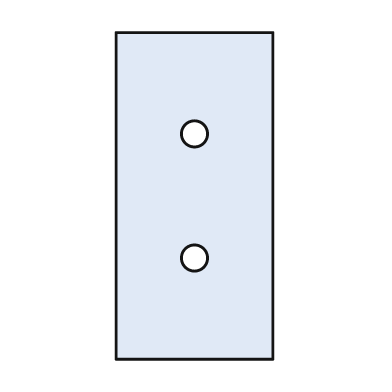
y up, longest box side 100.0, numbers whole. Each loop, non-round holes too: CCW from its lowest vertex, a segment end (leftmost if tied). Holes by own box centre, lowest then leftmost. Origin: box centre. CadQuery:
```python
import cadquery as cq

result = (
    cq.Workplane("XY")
    .moveTo(-24.0, -50.0)
    .lineTo(24.0, -50.0)
    .lineTo(24.0, 50.0)
    .lineTo(-24.0, 50.0)
    .close()
    .moveTo(0.0, -19.0)
    .circle(4.0)
    .moveTo(0.0, 19.0)
    .circle(4.0)
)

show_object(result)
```